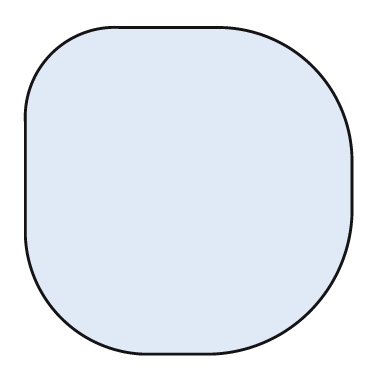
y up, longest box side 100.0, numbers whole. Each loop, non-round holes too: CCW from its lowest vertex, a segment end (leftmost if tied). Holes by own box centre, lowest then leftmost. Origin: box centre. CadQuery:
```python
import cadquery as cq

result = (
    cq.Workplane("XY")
    .moveTo(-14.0, -50.0)
    .lineTo(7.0, -50.0)
    .threePointArc((37.0, -37.0), (50.0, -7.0))
    .lineTo(50.0, 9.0)
    .threePointArc((38.0, 38.0), (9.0, 50.0))
    .lineTo(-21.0, 50.0)
    .threePointArc((-42.0, 42.0), (-50.0, 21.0))
    .lineTo(-50.0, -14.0)
    .threePointArc((-39.0, -39.0), (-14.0, -50.0))
    .close()
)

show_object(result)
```